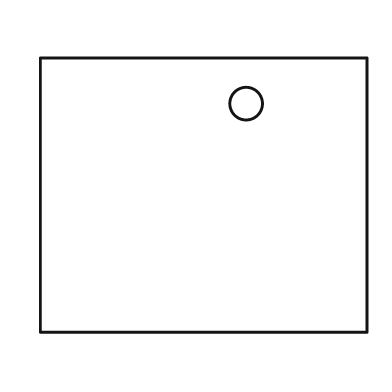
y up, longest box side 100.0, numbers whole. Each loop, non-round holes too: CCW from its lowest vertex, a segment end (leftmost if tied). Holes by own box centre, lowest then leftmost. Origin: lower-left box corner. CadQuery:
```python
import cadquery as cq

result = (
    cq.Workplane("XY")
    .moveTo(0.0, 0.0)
    .lineTo(100.0, 0.0)
    .lineTo(100.0, 84.0)
    .lineTo(0.0, 84.0)
    .close()
    .moveTo(63.0, 70.0)
    .circle(5.0)
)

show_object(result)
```